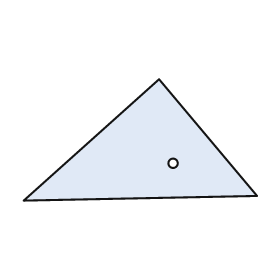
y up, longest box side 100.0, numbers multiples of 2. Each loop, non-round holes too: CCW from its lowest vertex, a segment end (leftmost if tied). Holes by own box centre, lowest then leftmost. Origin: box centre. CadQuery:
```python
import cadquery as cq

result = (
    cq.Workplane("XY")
    .moveTo(-50.0, -26.0)
    .lineTo(50.0, -24.0)
    .lineTo(8.0, 26.0)
    .close()
    .moveTo(14.0, -10.0)
    .circle(2.0)
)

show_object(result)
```